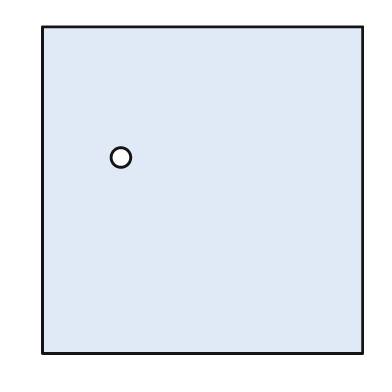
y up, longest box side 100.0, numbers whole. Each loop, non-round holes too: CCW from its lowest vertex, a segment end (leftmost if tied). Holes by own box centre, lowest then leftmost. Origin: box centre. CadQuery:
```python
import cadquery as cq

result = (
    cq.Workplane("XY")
    .moveTo(-49.0, -50.0)
    .lineTo(49.0, -50.0)
    .lineTo(49.0, 50.0)
    .lineTo(-49.0, 50.0)
    .close()
    .moveTo(-25.0, 10.0)
    .circle(3.0)
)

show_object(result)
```